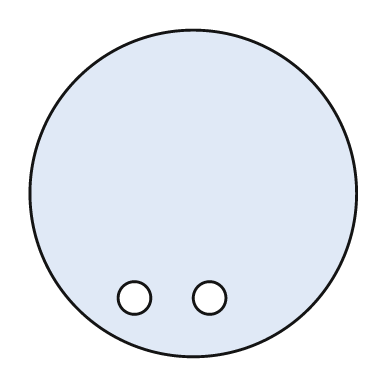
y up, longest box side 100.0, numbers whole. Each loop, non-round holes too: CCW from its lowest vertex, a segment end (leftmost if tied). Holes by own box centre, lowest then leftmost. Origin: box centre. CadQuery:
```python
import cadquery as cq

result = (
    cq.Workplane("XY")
    .moveTo(0.0, 0.0)
    .circle(50.0)
    .moveTo(-18.0, -32.0)
    .circle(5.0)
    .moveTo(5.0, -32.0)
    .circle(5.0)
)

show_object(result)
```